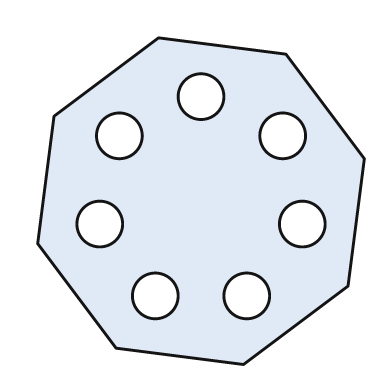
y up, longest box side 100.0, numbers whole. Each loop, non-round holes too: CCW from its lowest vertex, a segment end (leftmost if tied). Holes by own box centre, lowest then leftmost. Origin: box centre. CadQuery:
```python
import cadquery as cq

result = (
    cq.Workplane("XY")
    .moveTo(13.0, -50.0)
    .lineTo(45.0, -26.0)
    .lineTo(50.0, 13.0)
    .lineTo(26.0, 45.0)
    .lineTo(-13.0, 50.0)
    .lineTo(-45.0, 26.0)
    .lineTo(-50.0, -13.0)
    .lineTo(-26.0, -45.0)
    .close()
    .moveTo(-14.0, -29.0)
    .circle(7.0)
    .moveTo(14.0, -29.0)
    .circle(7.0)
    .moveTo(-31.0, -7.0)
    .circle(7.0)
    .moveTo(31.0, -7.0)
    .circle(7.0)
    .moveTo(-25.0, 20.0)
    .circle(7.0)
    .moveTo(25.0, 20.0)
    .circle(7.0)
    .moveTo(0.0, 32.0)
    .circle(7.0)
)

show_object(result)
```